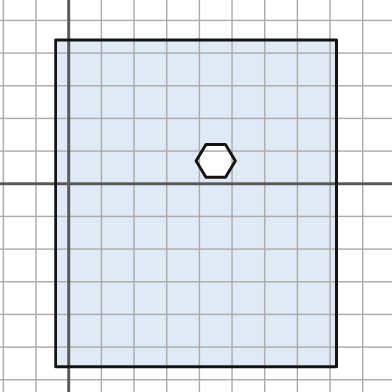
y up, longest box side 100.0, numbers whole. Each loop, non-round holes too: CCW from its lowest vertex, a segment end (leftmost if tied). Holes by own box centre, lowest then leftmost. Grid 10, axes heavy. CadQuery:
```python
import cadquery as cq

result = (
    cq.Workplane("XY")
    .moveTo(-4.0, -56.0)
    .lineTo(82.0, -56.0)
    .lineTo(82.0, 44.0)
    .lineTo(-4.0, 44.0)
    .close()
    .moveTo(42.0, 2.0)
    .lineTo(48.0, 2.0)
    .lineTo(51.0, 7.0)
    .lineTo(48.0, 12.0)
    .lineTo(42.0, 12.0)
    .lineTo(39.0, 7.0)
    .close()
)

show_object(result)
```